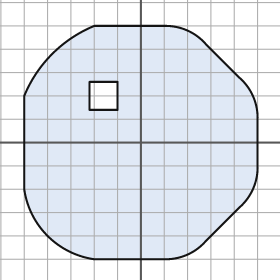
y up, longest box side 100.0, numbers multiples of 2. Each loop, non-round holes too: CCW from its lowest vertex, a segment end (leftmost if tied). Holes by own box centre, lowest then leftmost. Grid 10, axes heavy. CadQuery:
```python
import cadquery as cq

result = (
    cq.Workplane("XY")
    .moveTo(-20.0, -50.0)
    .lineTo(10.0, -50.0)
    .threePointArc((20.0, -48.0), (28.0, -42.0))
    .lineTo(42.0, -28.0)
    .threePointArc((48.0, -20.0), (50.0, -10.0))
    .lineTo(50.0, 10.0)
    .threePointArc((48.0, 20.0), (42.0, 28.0))
    .lineTo(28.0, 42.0)
    .threePointArc((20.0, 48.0), (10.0, 50.0))
    .lineTo(-20.0, 50.0)
    .threePointArc((-38.0, 38.0), (-50.0, 20.0))
    .lineTo(-50.0, -20.0)
    .threePointArc((-40.0, -40.0), (-20.0, -50.0))
    .close()
    .moveTo(-22.0, 14.0)
    .lineTo(-10.0, 14.0)
    .lineTo(-10.0, 26.0)
    .lineTo(-22.0, 26.0)
    .close()
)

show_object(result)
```